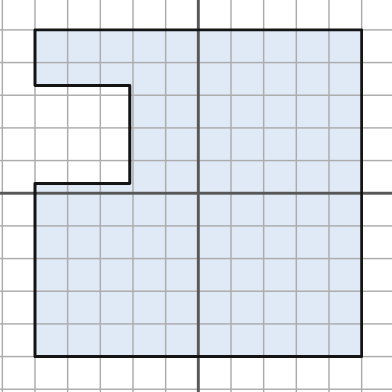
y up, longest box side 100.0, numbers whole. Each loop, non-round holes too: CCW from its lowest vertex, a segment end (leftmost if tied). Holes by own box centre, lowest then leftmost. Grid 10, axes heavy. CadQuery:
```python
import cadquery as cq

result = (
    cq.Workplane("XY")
    .moveTo(-50.0, -50.0)
    .lineTo(50.0, -50.0)
    .lineTo(50.0, 50.0)
    .lineTo(-50.0, 50.0)
    .lineTo(-50.0, 33.0)
    .lineTo(-21.0, 33.0)
    .lineTo(-21.0, 3.0)
    .lineTo(-50.0, 3.0)
    .close()
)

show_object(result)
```